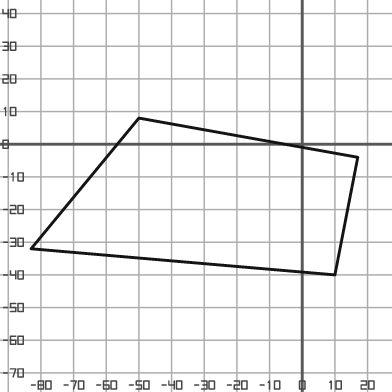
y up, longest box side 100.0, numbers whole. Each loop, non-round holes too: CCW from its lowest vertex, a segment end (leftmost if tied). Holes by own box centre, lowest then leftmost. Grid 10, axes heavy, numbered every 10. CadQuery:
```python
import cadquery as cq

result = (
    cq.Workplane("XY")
    .moveTo(10.0, -40.0)
    .lineTo(17.0, -4.0)
    .lineTo(-50.0, 8.0)
    .lineTo(-83.0, -32.0)
    .close()
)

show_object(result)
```